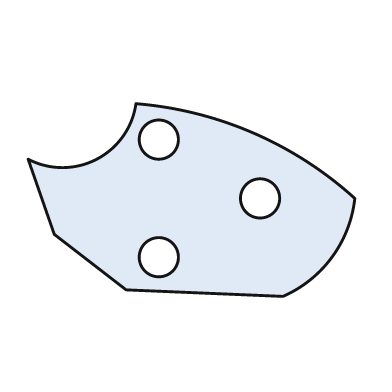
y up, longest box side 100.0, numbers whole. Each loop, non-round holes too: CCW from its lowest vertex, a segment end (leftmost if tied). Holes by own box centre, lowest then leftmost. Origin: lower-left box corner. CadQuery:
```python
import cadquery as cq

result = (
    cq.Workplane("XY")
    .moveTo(78.0, 0.0)
    .threePointArc((93.0, 12.0), (100.0, 30.0))
    .threePointArc((69.0, 50.0), (33.0, 59.0))
    .threePointArc((21.0, 42.0), (0.0, 42.0))
    .lineTo(8.0, 19.0)
    .lineTo(30.0, 2.0)
    .close()
    .moveTo(40.0, 12.0)
    .circle(6.0)
    .moveTo(71.0, 30.0)
    .circle(6.0)
    .moveTo(40.0, 48.0)
    .circle(6.0)
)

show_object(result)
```